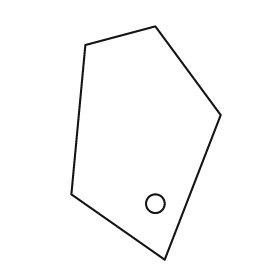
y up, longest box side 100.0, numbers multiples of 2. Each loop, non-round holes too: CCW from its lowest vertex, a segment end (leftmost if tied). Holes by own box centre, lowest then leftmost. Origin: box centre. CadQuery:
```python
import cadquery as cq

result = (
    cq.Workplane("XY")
    .moveTo(8.0, -50.0)
    .lineTo(32.0, 12.0)
    .lineTo(4.0, 50.0)
    .lineTo(-26.0, 42.0)
    .lineTo(-32.0, -22.0)
    .close()
    .moveTo(4.0, -26.0)
    .circle(4.0)
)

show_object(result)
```